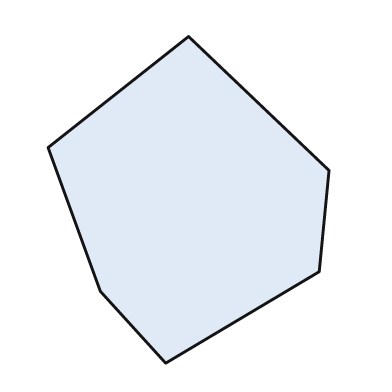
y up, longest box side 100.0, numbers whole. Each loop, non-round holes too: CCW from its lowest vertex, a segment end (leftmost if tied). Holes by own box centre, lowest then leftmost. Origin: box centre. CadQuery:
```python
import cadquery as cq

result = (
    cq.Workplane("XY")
    .moveTo(-7.0, -50.0)
    .lineTo(40.0, -22.0)
    .lineTo(43.0, 9.0)
    .lineTo(0.0, 50.0)
    .lineTo(-43.0, 16.0)
    .lineTo(-27.0, -28.0)
    .close()
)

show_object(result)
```